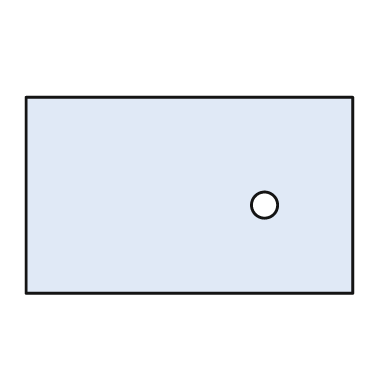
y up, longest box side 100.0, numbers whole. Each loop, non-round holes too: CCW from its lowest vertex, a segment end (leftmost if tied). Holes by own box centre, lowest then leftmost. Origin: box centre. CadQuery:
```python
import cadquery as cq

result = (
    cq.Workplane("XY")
    .moveTo(-50.0, -30.0)
    .lineTo(50.0, -30.0)
    .lineTo(50.0, 30.0)
    .lineTo(-50.0, 30.0)
    .close()
    .moveTo(23.0, -3.0)
    .circle(4.0)
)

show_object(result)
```